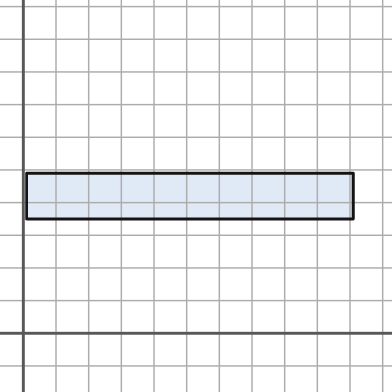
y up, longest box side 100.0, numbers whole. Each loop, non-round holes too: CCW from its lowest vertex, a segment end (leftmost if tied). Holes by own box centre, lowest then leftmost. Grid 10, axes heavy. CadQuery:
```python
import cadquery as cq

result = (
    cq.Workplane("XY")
    .moveTo(1.0, 35.0)
    .lineTo(101.0, 35.0)
    .lineTo(101.0, 49.0)
    .lineTo(1.0, 49.0)
    .close()
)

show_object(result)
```